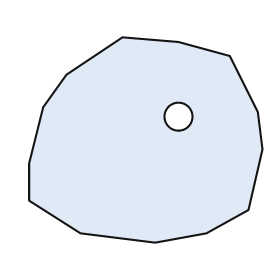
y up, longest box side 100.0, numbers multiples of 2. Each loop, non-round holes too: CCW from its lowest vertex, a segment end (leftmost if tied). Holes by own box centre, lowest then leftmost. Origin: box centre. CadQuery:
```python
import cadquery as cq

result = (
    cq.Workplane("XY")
    .moveTo(4.0, -44.0)
    .lineTo(26.0, -40.0)
    .lineTo(44.0, -30.0)
    .lineTo(50.0, -4.0)
    .lineTo(48.0, 12.0)
    .lineTo(36.0, 36.0)
    .lineTo(14.0, 42.0)
    .lineTo(-10.0, 44.0)
    .lineTo(-34.0, 28.0)
    .lineTo(-44.0, 14.0)
    .lineTo(-50.0, -10.0)
    .lineTo(-50.0, -26.0)
    .lineTo(-28.0, -40.0)
    .close()
    .moveTo(14.0, 10.0)
    .circle(6.0)
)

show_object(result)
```